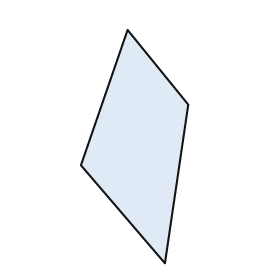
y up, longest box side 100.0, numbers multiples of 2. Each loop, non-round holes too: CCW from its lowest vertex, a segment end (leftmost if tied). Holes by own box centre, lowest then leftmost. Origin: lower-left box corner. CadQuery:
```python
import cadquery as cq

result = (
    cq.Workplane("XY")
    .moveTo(36.0, 0.0)
    .lineTo(46.0, 68.0)
    .lineTo(20.0, 100.0)
    .lineTo(0.0, 42.0)
    .close()
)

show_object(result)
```